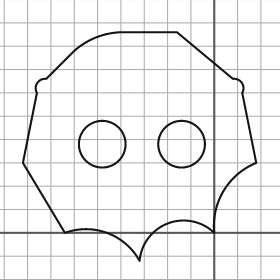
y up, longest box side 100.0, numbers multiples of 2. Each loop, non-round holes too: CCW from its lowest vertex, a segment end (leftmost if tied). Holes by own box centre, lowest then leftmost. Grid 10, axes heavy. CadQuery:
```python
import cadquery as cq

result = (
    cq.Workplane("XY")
    .moveTo(-32.0, -12.0)
    .threePointArc((-20.0, 4.0), (0.0, 0.0))
    .threePointArc((4.0, 18.0), (18.0, 30.0))
    .lineTo(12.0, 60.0)
    .threePointArc((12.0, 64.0), (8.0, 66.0))
    .lineTo(-16.0, 86.0)
    .lineTo(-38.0, 86.0)
    .threePointArc((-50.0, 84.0), (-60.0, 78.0))
    .lineTo(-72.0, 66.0)
    .threePointArc((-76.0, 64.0), (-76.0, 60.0))
    .lineTo(-82.0, 30.0)
    .lineTo(-64.0, 0.0)
    .threePointArc((-46.0, 0.0), (-32.0, -12.0))
    .close()
    .moveTo(-48.0, 38.0)
    .circle(10.0)
    .moveTo(-14.0, 38.0)
    .circle(10.0)
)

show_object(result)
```